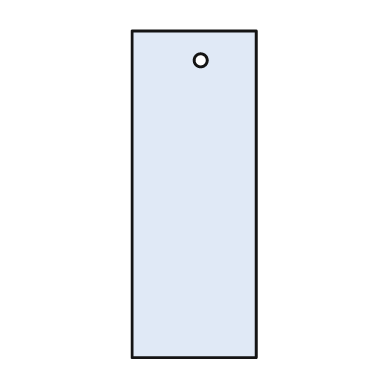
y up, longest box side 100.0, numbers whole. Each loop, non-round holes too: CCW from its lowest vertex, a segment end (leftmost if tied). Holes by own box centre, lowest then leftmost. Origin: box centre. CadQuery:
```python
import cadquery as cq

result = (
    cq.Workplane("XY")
    .moveTo(-19.0, -50.0)
    .lineTo(19.0, -50.0)
    .lineTo(19.0, 50.0)
    .lineTo(-19.0, 50.0)
    .close()
    .moveTo(2.0, 41.0)
    .circle(2.0)
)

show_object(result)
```